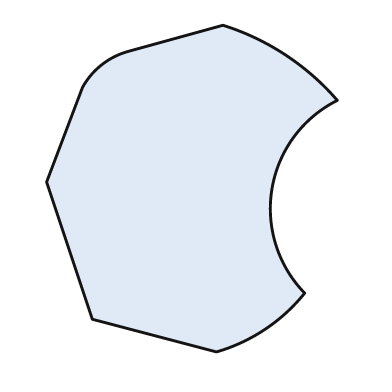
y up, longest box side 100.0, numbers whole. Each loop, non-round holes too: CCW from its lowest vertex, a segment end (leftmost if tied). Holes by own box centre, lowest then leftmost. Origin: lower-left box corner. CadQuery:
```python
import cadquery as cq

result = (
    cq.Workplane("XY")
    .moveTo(52.0, 0.0)
    .threePointArc((67.0, 7.0), (79.0, 18.0))
    .threePointArc((69.0, 50.0), (89.0, 77.0))
    .threePointArc((73.0, 91.0), (54.0, 100.0))
    .lineTo(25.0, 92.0)
    .threePointArc((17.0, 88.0), (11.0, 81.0))
    .lineTo(0.0, 52.0)
    .lineTo(14.0, 10.0)
    .close()
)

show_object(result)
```